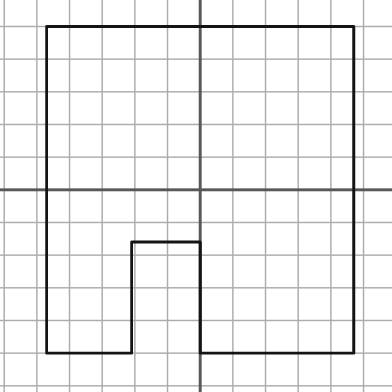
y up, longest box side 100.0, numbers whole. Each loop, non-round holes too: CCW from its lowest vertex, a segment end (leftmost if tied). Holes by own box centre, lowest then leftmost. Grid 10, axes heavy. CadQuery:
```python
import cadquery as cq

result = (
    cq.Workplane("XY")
    .moveTo(-47.0, -50.0)
    .lineTo(-21.0, -50.0)
    .lineTo(-21.0, -16.0)
    .lineTo(0.0, -16.0)
    .lineTo(0.0, -50.0)
    .lineTo(47.0, -50.0)
    .lineTo(47.0, 50.0)
    .lineTo(-47.0, 50.0)
    .close()
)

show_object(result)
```